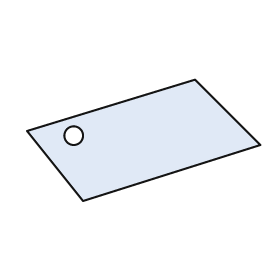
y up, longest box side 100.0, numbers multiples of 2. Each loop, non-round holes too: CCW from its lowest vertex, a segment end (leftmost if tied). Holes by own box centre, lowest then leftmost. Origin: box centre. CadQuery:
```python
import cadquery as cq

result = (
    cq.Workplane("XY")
    .moveTo(-26.0, -26.0)
    .lineTo(50.0, -2.0)
    .lineTo(22.0, 26.0)
    .lineTo(-50.0, 4.0)
    .close()
    .moveTo(-30.0, 2.0)
    .circle(4.0)
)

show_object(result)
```